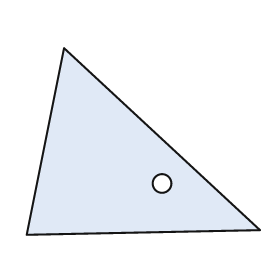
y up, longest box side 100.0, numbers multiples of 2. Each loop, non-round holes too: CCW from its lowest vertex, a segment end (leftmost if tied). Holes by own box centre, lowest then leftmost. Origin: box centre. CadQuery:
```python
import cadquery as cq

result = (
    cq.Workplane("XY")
    .moveTo(-50.0, -40.0)
    .lineTo(50.0, -38.0)
    .lineTo(-34.0, 40.0)
    .close()
    .moveTo(8.0, -18.0)
    .circle(4.0)
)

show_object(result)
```